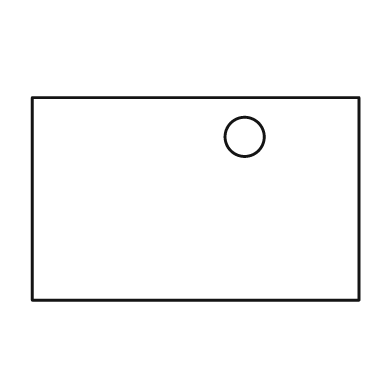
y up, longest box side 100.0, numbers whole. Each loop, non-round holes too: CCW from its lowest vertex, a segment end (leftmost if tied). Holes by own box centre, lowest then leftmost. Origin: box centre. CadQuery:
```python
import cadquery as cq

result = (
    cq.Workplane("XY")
    .moveTo(-50.0, -31.0)
    .lineTo(50.0, -31.0)
    .lineTo(50.0, 31.0)
    .lineTo(-50.0, 31.0)
    .close()
    .moveTo(15.0, 19.0)
    .circle(6.0)
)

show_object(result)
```